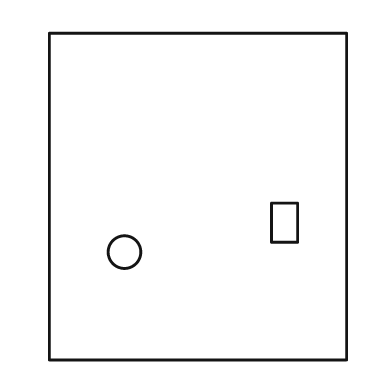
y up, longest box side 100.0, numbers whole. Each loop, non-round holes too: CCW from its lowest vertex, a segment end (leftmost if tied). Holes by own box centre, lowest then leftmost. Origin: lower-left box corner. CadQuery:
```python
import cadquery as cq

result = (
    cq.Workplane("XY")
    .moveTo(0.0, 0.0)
    .lineTo(91.0, 0.0)
    .lineTo(91.0, 100.0)
    .lineTo(0.0, 100.0)
    .close()
    .moveTo(23.0, 33.0)
    .circle(5.0)
    .moveTo(68.0, 36.0)
    .lineTo(76.0, 36.0)
    .lineTo(76.0, 48.0)
    .lineTo(68.0, 48.0)
    .close()
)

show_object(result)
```